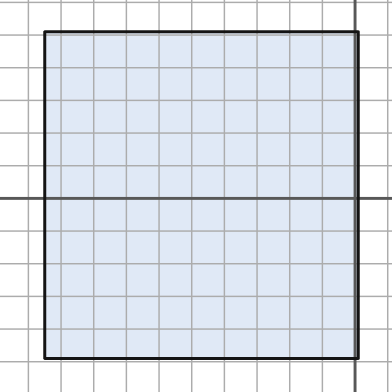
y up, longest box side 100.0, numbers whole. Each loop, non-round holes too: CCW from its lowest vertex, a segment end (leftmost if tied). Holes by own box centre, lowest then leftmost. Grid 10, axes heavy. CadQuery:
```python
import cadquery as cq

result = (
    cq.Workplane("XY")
    .moveTo(-95.0, -49.0)
    .lineTo(1.0, -49.0)
    .lineTo(1.0, 51.0)
    .lineTo(-95.0, 51.0)
    .close()
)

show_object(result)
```